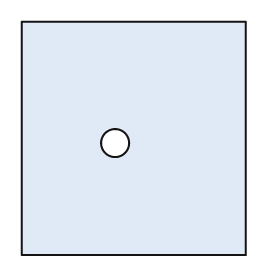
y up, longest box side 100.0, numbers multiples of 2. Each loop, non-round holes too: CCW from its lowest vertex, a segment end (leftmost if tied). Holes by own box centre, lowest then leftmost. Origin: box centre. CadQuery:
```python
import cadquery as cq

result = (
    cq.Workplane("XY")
    .moveTo(-48.0, -50.0)
    .lineTo(48.0, -50.0)
    .lineTo(48.0, 50.0)
    .lineTo(-48.0, 50.0)
    .close()
    .moveTo(-8.0, -2.0)
    .circle(6.0)
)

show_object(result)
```